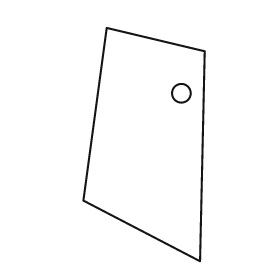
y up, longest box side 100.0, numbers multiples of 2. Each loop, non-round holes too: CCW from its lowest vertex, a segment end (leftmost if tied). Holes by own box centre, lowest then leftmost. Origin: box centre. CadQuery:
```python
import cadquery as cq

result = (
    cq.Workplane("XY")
    .moveTo(24.0, -50.0)
    .lineTo(26.0, 40.0)
    .lineTo(-16.0, 50.0)
    .lineTo(-26.0, -24.0)
    .close()
    .moveTo(16.0, 22.0)
    .circle(4.0)
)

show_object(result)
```